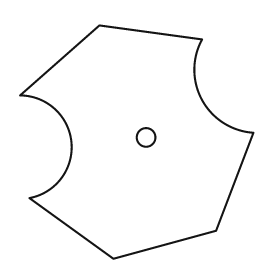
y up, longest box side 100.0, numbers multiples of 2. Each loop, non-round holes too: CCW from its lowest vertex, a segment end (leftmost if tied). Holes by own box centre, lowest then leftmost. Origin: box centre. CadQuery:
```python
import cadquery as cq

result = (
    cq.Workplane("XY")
    .moveTo(-10.0, -50.0)
    .lineTo(34.0, -38.0)
    .lineTo(50.0, 4.0)
    .threePointArc((28.0, 18.0), (28.0, 44.0))
    .lineTo(-16.0, 50.0)
    .lineTo(-50.0, 20.0)
    .threePointArc((-28.0, 0.0), (-46.0, -24.0))
    .close()
    .moveTo(4.0, 2.0)
    .circle(4.0)
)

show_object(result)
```